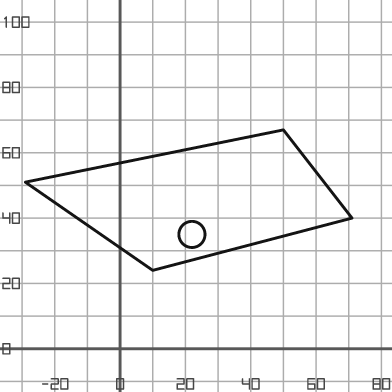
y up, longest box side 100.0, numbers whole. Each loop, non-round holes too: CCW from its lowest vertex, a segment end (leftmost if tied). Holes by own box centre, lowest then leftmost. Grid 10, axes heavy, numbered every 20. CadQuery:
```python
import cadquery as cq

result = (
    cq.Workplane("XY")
    .moveTo(10.0, 24.0)
    .lineTo(71.0, 40.0)
    .lineTo(50.0, 67.0)
    .lineTo(-29.0, 51.0)
    .close()
    .moveTo(22.0, 35.0)
    .circle(4.0)
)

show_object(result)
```